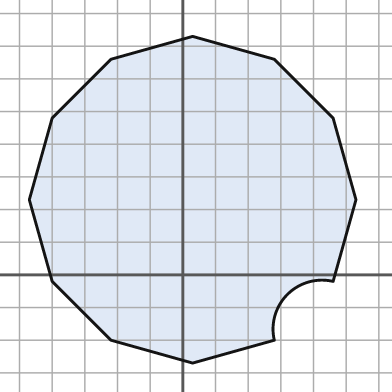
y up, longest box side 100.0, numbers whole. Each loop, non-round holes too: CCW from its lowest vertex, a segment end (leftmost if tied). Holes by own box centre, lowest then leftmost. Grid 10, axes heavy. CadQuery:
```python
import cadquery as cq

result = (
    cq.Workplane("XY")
    .moveTo(3.0, -27.0)
    .lineTo(28.0, -20.0)
    .threePointArc((32.0, -6.0), (46.0, -2.0))
    .lineTo(53.0, 23.0)
    .lineTo(46.0, 48.0)
    .lineTo(28.0, 66.0)
    .lineTo(3.0, 73.0)
    .lineTo(-22.0, 66.0)
    .lineTo(-40.0, 48.0)
    .lineTo(-47.0, 23.0)
    .lineTo(-40.0, -2.0)
    .lineTo(-22.0, -20.0)
    .close()
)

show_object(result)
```